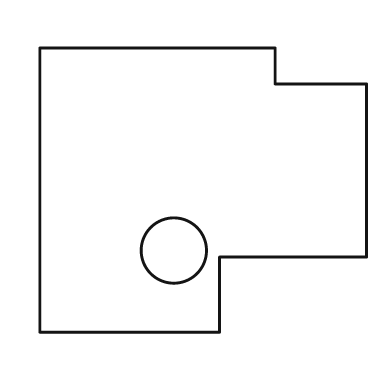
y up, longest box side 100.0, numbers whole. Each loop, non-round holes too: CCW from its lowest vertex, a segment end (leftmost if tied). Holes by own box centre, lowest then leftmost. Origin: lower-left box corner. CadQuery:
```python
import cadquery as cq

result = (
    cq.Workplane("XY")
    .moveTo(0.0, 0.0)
    .lineTo(55.0, 0.0)
    .lineTo(55.0, 23.0)
    .lineTo(100.0, 23.0)
    .lineTo(100.0, 76.0)
    .lineTo(72.0, 76.0)
    .lineTo(72.0, 87.0)
    .lineTo(0.0, 87.0)
    .close()
    .moveTo(41.0, 25.0)
    .circle(10.0)
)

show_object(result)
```